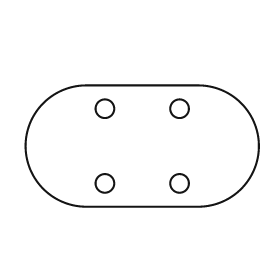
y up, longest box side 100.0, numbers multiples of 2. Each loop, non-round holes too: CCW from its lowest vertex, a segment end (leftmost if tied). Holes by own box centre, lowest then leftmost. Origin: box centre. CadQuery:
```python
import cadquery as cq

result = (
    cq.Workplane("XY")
    .moveTo(-24.0, -26.0)
    .lineTo(24.0, -26.0)
    .threePointArc((50.0, 0.0), (24.0, 26.0))
    .lineTo(-24.0, 26.0)
    .threePointArc((-50.0, 0.0), (-24.0, -26.0))
    .close()
    .moveTo(-16.0, -16.0)
    .circle(4.0)
    .moveTo(16.0, -16.0)
    .circle(4.0)
    .moveTo(-16.0, 16.0)
    .circle(4.0)
    .moveTo(16.0, 16.0)
    .circle(4.0)
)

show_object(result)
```